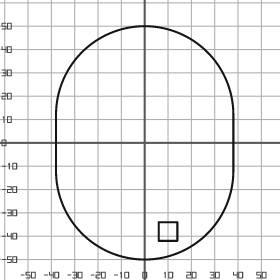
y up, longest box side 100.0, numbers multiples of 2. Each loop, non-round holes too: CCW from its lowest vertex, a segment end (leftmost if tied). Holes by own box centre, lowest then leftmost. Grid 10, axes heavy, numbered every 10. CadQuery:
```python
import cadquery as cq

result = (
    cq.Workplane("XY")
    .moveTo(-38.0, -12.0)
    .threePointArc((0.0, -50.0), (38.0, -12.0))
    .lineTo(38.0, 12.0)
    .threePointArc((0.0, 50.0), (-38.0, 12.0))
    .close()
    .moveTo(6.0, -42.0)
    .lineTo(14.0, -42.0)
    .lineTo(14.0, -34.0)
    .lineTo(6.0, -34.0)
    .close()
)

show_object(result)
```